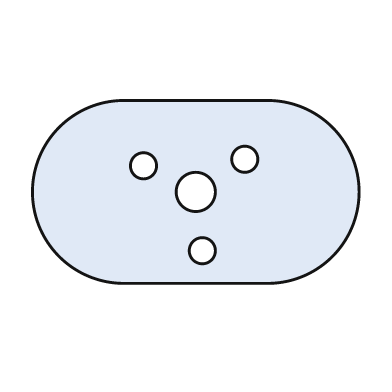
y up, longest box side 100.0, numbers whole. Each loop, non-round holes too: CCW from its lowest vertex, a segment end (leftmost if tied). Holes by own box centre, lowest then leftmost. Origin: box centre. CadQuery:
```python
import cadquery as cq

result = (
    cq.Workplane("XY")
    .moveTo(-22.0, -28.0)
    .lineTo(22.0, -28.0)
    .threePointArc((50.0, 0.0), (22.0, 28.0))
    .lineTo(-22.0, 28.0)
    .threePointArc((-50.0, 0.0), (-22.0, -28.0))
    .close()
    .moveTo(2.0, -18.0)
    .circle(4.0)
    .moveTo(0.0, 0.0)
    .circle(6.0)
    .moveTo(-16.0, 8.0)
    .circle(4.0)
    .moveTo(15.0, 10.0)
    .circle(4.0)
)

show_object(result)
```